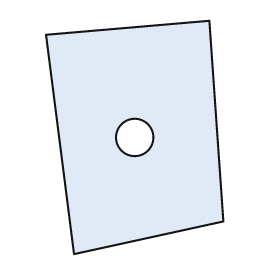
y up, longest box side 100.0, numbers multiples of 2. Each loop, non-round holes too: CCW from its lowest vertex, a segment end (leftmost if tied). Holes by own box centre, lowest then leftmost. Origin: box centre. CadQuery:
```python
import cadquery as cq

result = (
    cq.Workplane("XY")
    .moveTo(-26.0, -50.0)
    .lineTo(38.0, -36.0)
    .lineTo(32.0, 50.0)
    .lineTo(-38.0, 44.0)
    .close()
    .moveTo(0.0, 0.0)
    .circle(8.0)
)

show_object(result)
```